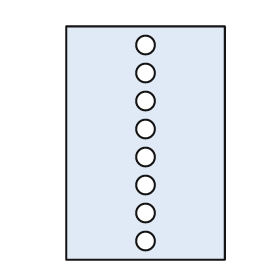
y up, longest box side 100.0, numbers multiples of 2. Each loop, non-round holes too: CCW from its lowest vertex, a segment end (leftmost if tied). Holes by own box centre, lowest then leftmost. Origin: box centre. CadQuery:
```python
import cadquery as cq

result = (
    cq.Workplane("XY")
    .moveTo(-34.0, -50.0)
    .lineTo(34.0, -50.0)
    .lineTo(34.0, 50.0)
    .lineTo(-34.0, 50.0)
    .close()
    .moveTo(0.0, -42.0)
    .circle(4.0)
    .moveTo(0.0, -30.0)
    .circle(4.0)
    .moveTo(0.0, -18.0)
    .circle(4.0)
    .moveTo(0.0, -6.0)
    .circle(4.0)
    .moveTo(0.0, 6.0)
    .circle(4.0)
    .moveTo(0.0, 18.0)
    .circle(4.0)
    .moveTo(0.0, 30.0)
    .circle(4.0)
    .moveTo(0.0, 42.0)
    .circle(4.0)
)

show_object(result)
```